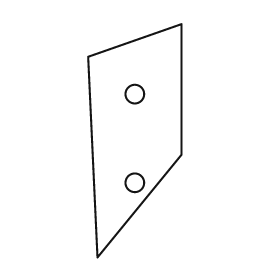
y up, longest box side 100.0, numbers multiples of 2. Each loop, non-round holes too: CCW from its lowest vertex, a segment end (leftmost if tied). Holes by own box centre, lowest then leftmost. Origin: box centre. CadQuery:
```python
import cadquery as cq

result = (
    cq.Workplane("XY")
    .moveTo(-16.0, -50.0)
    .lineTo(20.0, -6.0)
    .lineTo(20.0, 50.0)
    .lineTo(-20.0, 36.0)
    .close()
    .moveTo(0.0, -18.0)
    .circle(4.0)
    .moveTo(0.0, 20.0)
    .circle(4.0)
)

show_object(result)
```